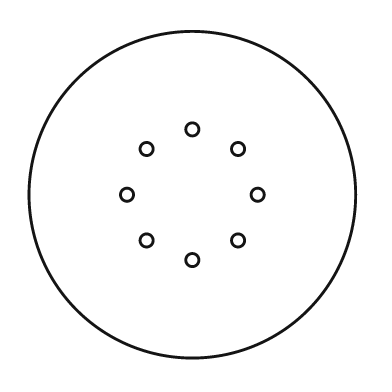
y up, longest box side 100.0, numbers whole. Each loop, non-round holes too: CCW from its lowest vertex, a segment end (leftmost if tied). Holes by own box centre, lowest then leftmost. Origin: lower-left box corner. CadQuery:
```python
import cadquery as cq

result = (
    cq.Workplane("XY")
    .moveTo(50.0, 50.0)
    .circle(50.0)
    .moveTo(50.0, 30.0)
    .circle(2.0)
    .moveTo(36.0, 36.0)
    .circle(2.0)
    .moveTo(64.0, 36.0)
    .circle(2.0)
    .moveTo(30.0, 50.0)
    .circle(2.0)
    .moveTo(70.0, 50.0)
    .circle(2.0)
    .moveTo(36.0, 64.0)
    .circle(2.0)
    .moveTo(64.0, 64.0)
    .circle(2.0)
    .moveTo(50.0, 70.0)
    .circle(2.0)
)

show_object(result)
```